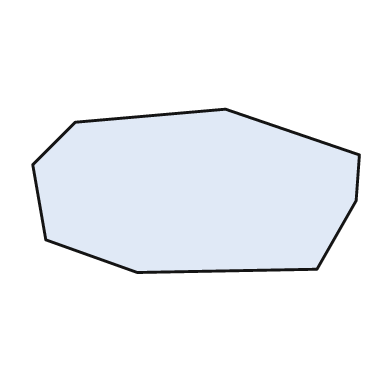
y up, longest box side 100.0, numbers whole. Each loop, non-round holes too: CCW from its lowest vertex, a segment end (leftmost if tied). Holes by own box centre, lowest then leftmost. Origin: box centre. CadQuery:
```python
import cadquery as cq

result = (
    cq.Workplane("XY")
    .moveTo(-18.0, -25.0)
    .lineTo(37.0, -24.0)
    .lineTo(49.0, -3.0)
    .lineTo(50.0, 11.0)
    .lineTo(9.0, 25.0)
    .lineTo(-37.0, 21.0)
    .lineTo(-50.0, 8.0)
    .lineTo(-46.0, -15.0)
    .close()
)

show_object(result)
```